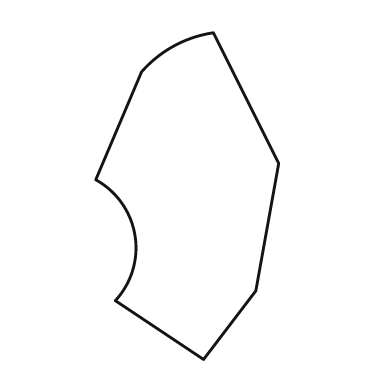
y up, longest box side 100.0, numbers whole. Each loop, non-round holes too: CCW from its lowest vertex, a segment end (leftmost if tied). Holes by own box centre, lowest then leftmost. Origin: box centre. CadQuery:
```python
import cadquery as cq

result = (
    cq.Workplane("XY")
    .moveTo(5.0, -50.0)
    .lineTo(21.0, -29.0)
    .lineTo(28.0, 10.0)
    .lineTo(8.0, 50.0)
    .threePointArc((-4.0, 46.0), (-14.0, 38.0))
    .lineTo(-28.0, 5.0)
    .threePointArc((-16.0, -12.0), (-22.0, -32.0))
    .close()
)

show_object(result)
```